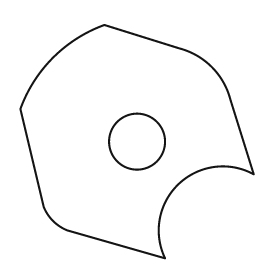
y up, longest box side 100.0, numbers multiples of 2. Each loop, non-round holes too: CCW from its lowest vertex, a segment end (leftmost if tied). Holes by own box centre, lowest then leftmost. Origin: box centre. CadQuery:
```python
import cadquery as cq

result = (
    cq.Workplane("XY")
    .moveTo(12.0, -50.0)
    .threePointArc((18.0, -18.0), (50.0, -14.0))
    .lineTo(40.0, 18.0)
    .threePointArc((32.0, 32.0), (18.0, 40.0))
    .lineTo(-14.0, 50.0)
    .threePointArc((-36.0, 36.0), (-50.0, 14.0))
    .lineTo(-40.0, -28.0)
    .threePointArc((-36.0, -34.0), (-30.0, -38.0))
    .close()
    .moveTo(0.0, 0.0)
    .circle(12.0)
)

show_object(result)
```